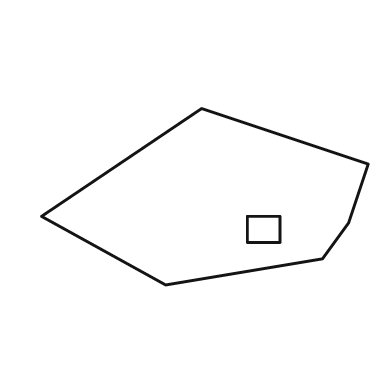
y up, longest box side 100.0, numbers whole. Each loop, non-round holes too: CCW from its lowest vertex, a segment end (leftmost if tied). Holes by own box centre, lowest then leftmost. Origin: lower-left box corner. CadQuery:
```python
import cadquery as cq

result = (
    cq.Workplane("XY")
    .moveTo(38.0, 0.0)
    .lineTo(86.0, 8.0)
    .lineTo(94.0, 19.0)
    .lineTo(100.0, 37.0)
    .lineTo(49.0, 54.0)
    .lineTo(0.0, 21.0)
    .close()
    .moveTo(63.0, 13.0)
    .lineTo(73.0, 13.0)
    .lineTo(73.0, 21.0)
    .lineTo(63.0, 21.0)
    .close()
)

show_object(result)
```